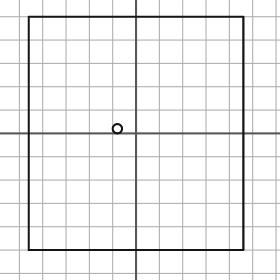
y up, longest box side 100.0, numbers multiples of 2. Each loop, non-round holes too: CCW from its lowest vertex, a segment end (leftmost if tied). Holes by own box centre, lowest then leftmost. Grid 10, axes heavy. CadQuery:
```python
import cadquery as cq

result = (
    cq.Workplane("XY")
    .moveTo(-46.0, -50.0)
    .lineTo(46.0, -50.0)
    .lineTo(46.0, 50.0)
    .lineTo(-46.0, 50.0)
    .close()
    .moveTo(-8.0, 2.0)
    .circle(2.0)
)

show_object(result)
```